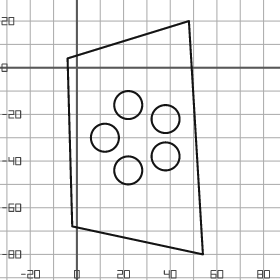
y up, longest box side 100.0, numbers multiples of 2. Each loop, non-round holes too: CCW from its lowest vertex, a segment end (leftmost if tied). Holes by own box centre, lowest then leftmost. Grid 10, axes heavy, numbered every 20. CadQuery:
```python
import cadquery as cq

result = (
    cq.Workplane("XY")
    .moveTo(54.0, -80.0)
    .lineTo(48.0, 20.0)
    .lineTo(-4.0, 4.0)
    .lineTo(-2.0, -68.0)
    .close()
    .moveTo(22.0, -44.0)
    .circle(6.0)
    .moveTo(38.0, -38.0)
    .circle(6.0)
    .moveTo(12.0, -30.0)
    .circle(6.0)
    .moveTo(38.0, -22.0)
    .circle(6.0)
    .moveTo(22.0, -16.0)
    .circle(6.0)
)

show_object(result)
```